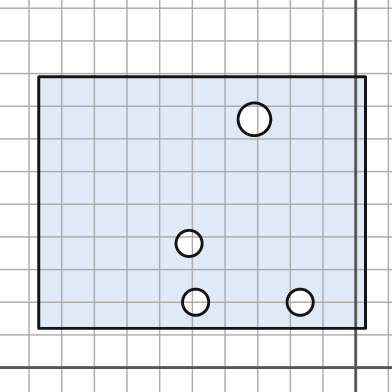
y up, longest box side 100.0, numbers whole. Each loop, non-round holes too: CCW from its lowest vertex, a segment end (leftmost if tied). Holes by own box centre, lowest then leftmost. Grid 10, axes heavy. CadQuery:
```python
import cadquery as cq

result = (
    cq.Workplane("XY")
    .moveTo(-97.0, 12.0)
    .lineTo(3.0, 12.0)
    .lineTo(3.0, 89.0)
    .lineTo(-97.0, 89.0)
    .close()
    .moveTo(-49.0, 20.0)
    .circle(4.0)
    .moveTo(-17.0, 20.0)
    .circle(4.0)
    .moveTo(-51.0, 38.0)
    .circle(4.0)
    .moveTo(-31.0, 76.0)
    .circle(5.0)
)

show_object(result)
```